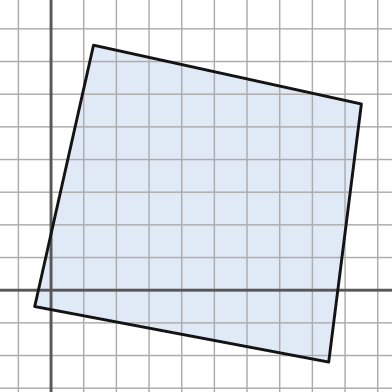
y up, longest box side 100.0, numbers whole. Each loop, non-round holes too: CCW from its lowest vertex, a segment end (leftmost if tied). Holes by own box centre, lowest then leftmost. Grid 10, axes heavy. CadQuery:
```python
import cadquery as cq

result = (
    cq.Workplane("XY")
    .moveTo(85.0, -22.0)
    .lineTo(95.0, 57.0)
    .lineTo(13.0, 75.0)
    .lineTo(-5.0, -5.0)
    .close()
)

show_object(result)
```